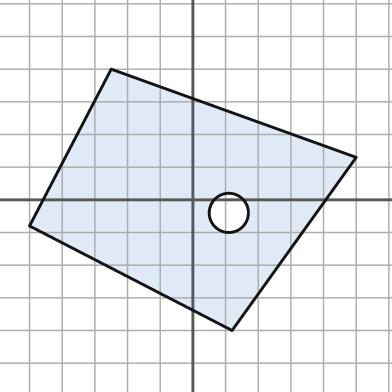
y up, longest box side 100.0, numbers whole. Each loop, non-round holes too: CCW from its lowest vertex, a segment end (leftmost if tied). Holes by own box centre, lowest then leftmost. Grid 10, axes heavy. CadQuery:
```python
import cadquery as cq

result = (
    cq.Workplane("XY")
    .moveTo(12.0, -40.0)
    .lineTo(50.0, 13.0)
    .lineTo(-25.0, 40.0)
    .lineTo(-50.0, -8.0)
    .close()
    .moveTo(11.0, -4.0)
    .circle(6.0)
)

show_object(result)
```